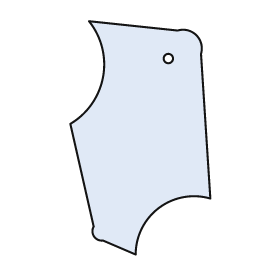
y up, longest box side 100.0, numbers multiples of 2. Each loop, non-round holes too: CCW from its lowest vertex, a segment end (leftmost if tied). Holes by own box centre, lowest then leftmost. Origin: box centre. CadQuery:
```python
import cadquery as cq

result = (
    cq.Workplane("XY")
    .moveTo(-2.0, -50.0)
    .threePointArc((8.0, -30.0), (30.0, -26.0))
    .lineTo(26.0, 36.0)
    .threePointArc((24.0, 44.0), (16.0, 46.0))
    .lineTo(-22.0, 50.0)
    .threePointArc((-16.0, 26.0), (-30.0, 6.0))
    .lineTo(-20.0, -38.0)
    .threePointArc((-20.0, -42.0), (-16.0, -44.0))
    .close()
    .moveTo(12.0, 34.0)
    .circle(2.0)
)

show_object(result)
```